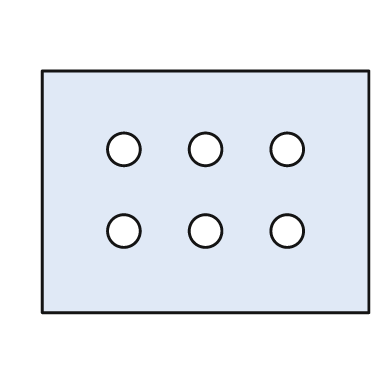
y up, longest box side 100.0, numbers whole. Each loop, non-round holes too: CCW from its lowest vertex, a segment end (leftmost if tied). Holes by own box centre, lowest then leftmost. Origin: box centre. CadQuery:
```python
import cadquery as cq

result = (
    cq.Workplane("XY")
    .moveTo(-50.0, -37.0)
    .lineTo(50.0, -37.0)
    .lineTo(50.0, 37.0)
    .lineTo(-50.0, 37.0)
    .close()
    .moveTo(-25.0, -12.0)
    .circle(5.0)
    .moveTo(0.0, -12.0)
    .circle(5.0)
    .moveTo(25.0, -12.0)
    .circle(5.0)
    .moveTo(-25.0, 13.0)
    .circle(5.0)
    .moveTo(0.0, 13.0)
    .circle(5.0)
    .moveTo(25.0, 13.0)
    .circle(5.0)
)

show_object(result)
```